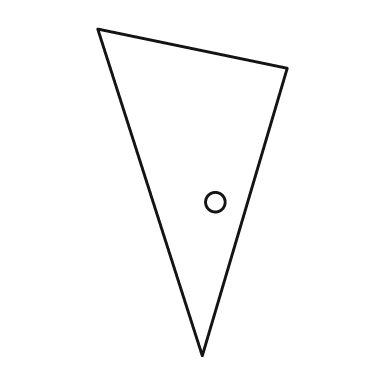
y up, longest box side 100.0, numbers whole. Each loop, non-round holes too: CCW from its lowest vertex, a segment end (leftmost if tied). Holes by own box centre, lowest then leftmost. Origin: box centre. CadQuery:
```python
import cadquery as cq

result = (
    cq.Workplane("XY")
    .moveTo(3.0, -50.0)
    .lineTo(29.0, 38.0)
    .lineTo(-29.0, 50.0)
    .close()
    .moveTo(7.0, -3.0)
    .circle(3.0)
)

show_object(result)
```